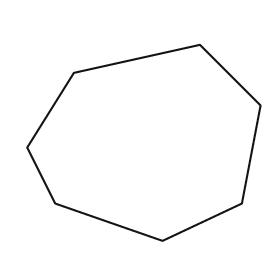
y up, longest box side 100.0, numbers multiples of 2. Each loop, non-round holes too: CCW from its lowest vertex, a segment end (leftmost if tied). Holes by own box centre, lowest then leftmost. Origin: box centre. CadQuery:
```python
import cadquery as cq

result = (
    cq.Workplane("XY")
    .moveTo(8.0, -42.0)
    .lineTo(42.0, -26.0)
    .lineTo(50.0, 16.0)
    .lineTo(24.0, 42.0)
    .lineTo(-30.0, 30.0)
    .lineTo(-50.0, -2.0)
    .lineTo(-38.0, -26.0)
    .close()
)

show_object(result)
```